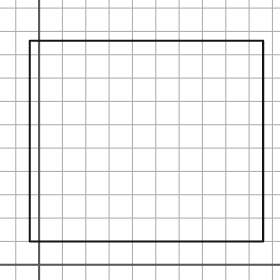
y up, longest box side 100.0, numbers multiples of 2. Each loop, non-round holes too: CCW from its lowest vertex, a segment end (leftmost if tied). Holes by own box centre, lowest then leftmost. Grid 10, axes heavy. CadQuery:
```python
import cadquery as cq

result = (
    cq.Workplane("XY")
    .moveTo(-4.0, 10.0)
    .lineTo(96.0, 10.0)
    .lineTo(96.0, 96.0)
    .lineTo(-4.0, 96.0)
    .close()
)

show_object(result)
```